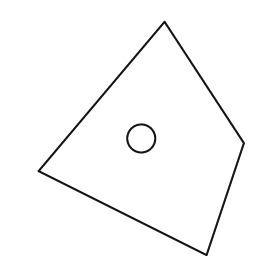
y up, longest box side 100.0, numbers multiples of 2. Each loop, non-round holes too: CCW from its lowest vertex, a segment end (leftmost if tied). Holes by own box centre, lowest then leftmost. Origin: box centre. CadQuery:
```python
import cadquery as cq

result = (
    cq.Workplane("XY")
    .moveTo(28.0, -50.0)
    .lineTo(44.0, -2.0)
    .lineTo(10.0, 50.0)
    .lineTo(-44.0, -14.0)
    .close()
    .moveTo(0.0, 0.0)
    .circle(6.0)
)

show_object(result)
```